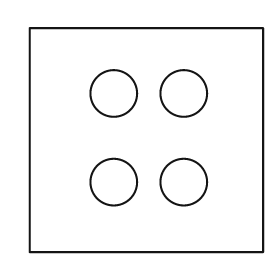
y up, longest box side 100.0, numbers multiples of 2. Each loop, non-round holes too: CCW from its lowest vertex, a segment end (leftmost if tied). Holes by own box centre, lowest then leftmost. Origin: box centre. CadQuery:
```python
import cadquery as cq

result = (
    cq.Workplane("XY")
    .moveTo(-50.0, -48.0)
    .lineTo(50.0, -48.0)
    .lineTo(50.0, 48.0)
    .lineTo(-50.0, 48.0)
    .close()
    .moveTo(-14.0, -18.0)
    .circle(10.0)
    .moveTo(16.0, -18.0)
    .circle(10.0)
    .moveTo(-14.0, 20.0)
    .circle(10.0)
    .moveTo(16.0, 20.0)
    .circle(10.0)
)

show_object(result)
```